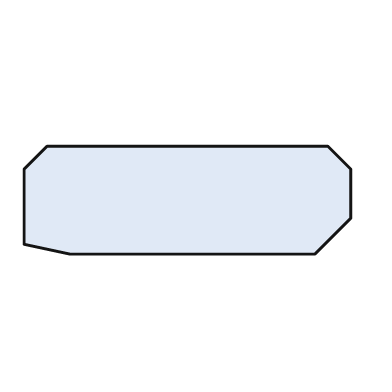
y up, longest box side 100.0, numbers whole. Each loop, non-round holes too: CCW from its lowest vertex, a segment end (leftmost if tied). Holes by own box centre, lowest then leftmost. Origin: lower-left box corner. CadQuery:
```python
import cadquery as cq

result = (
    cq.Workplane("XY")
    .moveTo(14.0, 0.0)
    .lineTo(89.0, 0.0)
    .lineTo(100.0, 11.0)
    .lineTo(100.0, 26.0)
    .lineTo(93.0, 33.0)
    .lineTo(7.0, 33.0)
    .lineTo(0.0, 26.0)
    .lineTo(0.0, 3.0)
    .close()
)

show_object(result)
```